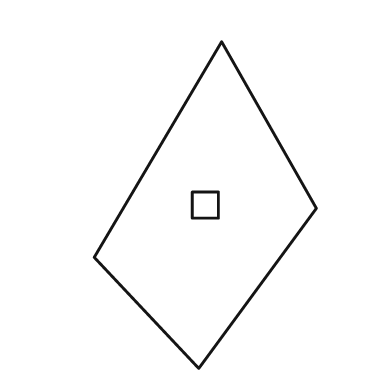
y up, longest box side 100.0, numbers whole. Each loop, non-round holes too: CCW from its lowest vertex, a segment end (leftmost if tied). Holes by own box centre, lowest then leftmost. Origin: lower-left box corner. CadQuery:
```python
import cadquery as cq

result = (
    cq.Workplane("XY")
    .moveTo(32.0, 0.0)
    .lineTo(68.0, 49.0)
    .lineTo(39.0, 100.0)
    .lineTo(0.0, 34.0)
    .close()
    .moveTo(30.0, 46.0)
    .lineTo(38.0, 46.0)
    .lineTo(38.0, 54.0)
    .lineTo(30.0, 54.0)
    .close()
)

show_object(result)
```